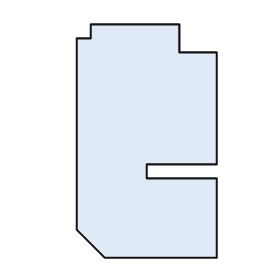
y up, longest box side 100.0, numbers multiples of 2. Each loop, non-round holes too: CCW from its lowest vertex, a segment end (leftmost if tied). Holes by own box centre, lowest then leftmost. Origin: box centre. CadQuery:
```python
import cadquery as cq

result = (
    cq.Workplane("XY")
    .moveTo(-18.0, -50.0)
    .lineTo(30.0, -50.0)
    .lineTo(30.0, -16.0)
    .lineTo(0.0, -16.0)
    .lineTo(0.0, -10.0)
    .lineTo(30.0, -10.0)
    .lineTo(30.0, 38.0)
    .lineTo(14.0, 38.0)
    .lineTo(14.0, 50.0)
    .lineTo(-24.0, 50.0)
    .lineTo(-24.0, 44.0)
    .lineTo(-30.0, 44.0)
    .lineTo(-30.0, -38.0)
    .close()
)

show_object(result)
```